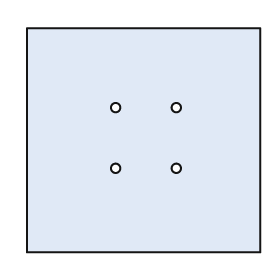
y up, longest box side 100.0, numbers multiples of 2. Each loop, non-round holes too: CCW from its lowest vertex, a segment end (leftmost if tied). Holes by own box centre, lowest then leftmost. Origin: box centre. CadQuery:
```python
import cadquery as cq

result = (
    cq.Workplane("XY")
    .moveTo(-50.0, -48.0)
    .lineTo(50.0, -48.0)
    .lineTo(50.0, 48.0)
    .lineTo(-50.0, 48.0)
    .close()
    .moveTo(-12.0, -12.0)
    .circle(2.0)
    .moveTo(14.0, -12.0)
    .circle(2.0)
    .moveTo(-12.0, 14.0)
    .circle(2.0)
    .moveTo(14.0, 14.0)
    .circle(2.0)
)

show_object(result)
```